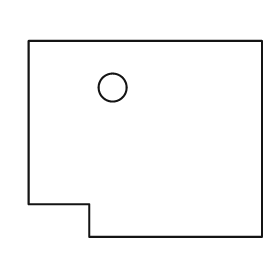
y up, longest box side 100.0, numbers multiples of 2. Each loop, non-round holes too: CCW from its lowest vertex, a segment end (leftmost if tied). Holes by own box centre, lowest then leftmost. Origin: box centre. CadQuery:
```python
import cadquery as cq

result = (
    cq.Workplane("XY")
    .moveTo(-24.0, -42.0)
    .lineTo(50.0, -42.0)
    .lineTo(50.0, 42.0)
    .lineTo(-50.0, 42.0)
    .lineTo(-50.0, -28.0)
    .lineTo(-24.0, -28.0)
    .close()
    .moveTo(-14.0, 22.0)
    .circle(6.0)
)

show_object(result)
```